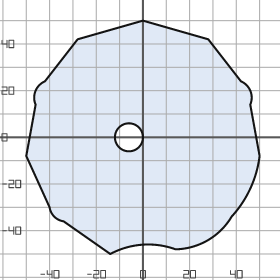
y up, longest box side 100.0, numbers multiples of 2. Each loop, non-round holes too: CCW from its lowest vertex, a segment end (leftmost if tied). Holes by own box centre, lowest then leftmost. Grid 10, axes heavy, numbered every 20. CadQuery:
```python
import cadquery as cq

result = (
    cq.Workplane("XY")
    .moveTo(-14.0, -50.0)
    .threePointArc((0.0, -46.0), (14.0, -48.0))
    .threePointArc((28.0, -44.0), (38.0, -34.0))
    .threePointArc((46.0, -22.0), (50.0, -8.0))
    .lineTo(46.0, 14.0)
    .threePointArc((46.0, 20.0), (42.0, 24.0))
    .lineTo(28.0, 42.0)
    .lineTo(0.0, 50.0)
    .lineTo(-28.0, 42.0)
    .lineTo(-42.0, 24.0)
    .threePointArc((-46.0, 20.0), (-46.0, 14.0))
    .lineTo(-50.0, -8.0)
    .lineTo(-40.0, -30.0)
    .threePointArc((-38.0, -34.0), (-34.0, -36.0))
    .close()
    .moveTo(-6.0, 0.0)
    .circle(6.0)
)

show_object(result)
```